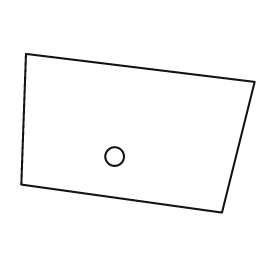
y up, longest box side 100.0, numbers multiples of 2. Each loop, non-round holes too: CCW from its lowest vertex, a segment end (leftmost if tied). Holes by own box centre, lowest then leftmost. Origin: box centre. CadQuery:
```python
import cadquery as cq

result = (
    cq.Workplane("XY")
    .moveTo(36.0, -34.0)
    .lineTo(50.0, 22.0)
    .lineTo(-48.0, 34.0)
    .lineTo(-50.0, -22.0)
    .close()
    .moveTo(-10.0, -10.0)
    .circle(4.0)
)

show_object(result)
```